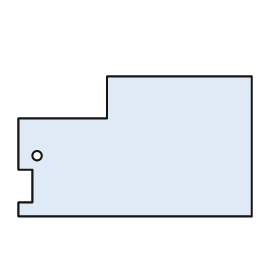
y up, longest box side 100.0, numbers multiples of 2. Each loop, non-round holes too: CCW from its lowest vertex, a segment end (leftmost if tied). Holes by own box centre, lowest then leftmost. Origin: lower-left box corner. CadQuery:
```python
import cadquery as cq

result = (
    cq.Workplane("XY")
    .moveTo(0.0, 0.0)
    .lineTo(100.0, 0.0)
    .lineTo(100.0, 60.0)
    .lineTo(38.0, 60.0)
    .lineTo(38.0, 42.0)
    .lineTo(0.0, 42.0)
    .lineTo(0.0, 20.0)
    .lineTo(6.0, 20.0)
    .lineTo(6.0, 6.0)
    .lineTo(0.0, 6.0)
    .close()
    .moveTo(8.0, 26.0)
    .circle(2.0)
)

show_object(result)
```